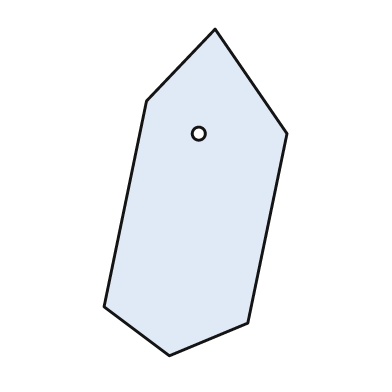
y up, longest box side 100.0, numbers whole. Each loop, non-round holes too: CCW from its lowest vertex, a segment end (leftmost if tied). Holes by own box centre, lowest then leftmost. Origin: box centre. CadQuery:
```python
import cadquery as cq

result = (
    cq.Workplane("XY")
    .moveTo(-8.0, -50.0)
    .lineTo(16.0, -40.0)
    .lineTo(28.0, 18.0)
    .lineTo(6.0, 50.0)
    .lineTo(-15.0, 28.0)
    .lineTo(-28.0, -35.0)
    .close()
    .moveTo(1.0, 18.0)
    .circle(2.0)
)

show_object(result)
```